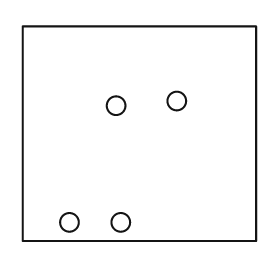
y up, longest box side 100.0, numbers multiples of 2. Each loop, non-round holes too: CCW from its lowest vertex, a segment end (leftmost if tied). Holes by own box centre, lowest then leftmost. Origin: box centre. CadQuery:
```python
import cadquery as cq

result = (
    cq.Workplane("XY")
    .moveTo(-50.0, -46.0)
    .lineTo(50.0, -46.0)
    .lineTo(50.0, 46.0)
    .lineTo(-50.0, 46.0)
    .close()
    .moveTo(-30.0, -38.0)
    .circle(4.0)
    .moveTo(-8.0, -38.0)
    .circle(4.0)
    .moveTo(-10.0, 12.0)
    .circle(4.0)
    .moveTo(16.0, 14.0)
    .circle(4.0)
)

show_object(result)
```